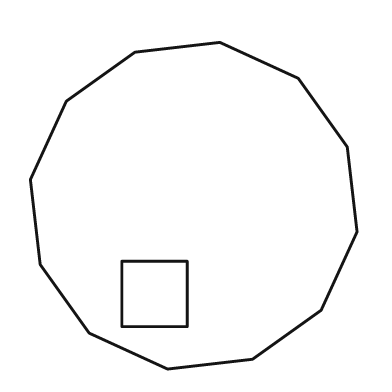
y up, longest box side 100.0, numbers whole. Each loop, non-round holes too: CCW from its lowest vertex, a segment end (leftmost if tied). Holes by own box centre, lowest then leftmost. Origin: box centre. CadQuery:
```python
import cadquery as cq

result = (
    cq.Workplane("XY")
    .moveTo(-8.0, -50.0)
    .lineTo(18.0, -47.0)
    .lineTo(39.0, -32.0)
    .lineTo(50.0, -8.0)
    .lineTo(47.0, 18.0)
    .lineTo(32.0, 39.0)
    .lineTo(8.0, 50.0)
    .lineTo(-18.0, 47.0)
    .lineTo(-39.0, 32.0)
    .lineTo(-50.0, 8.0)
    .lineTo(-47.0, -18.0)
    .lineTo(-32.0, -39.0)
    .close()
    .moveTo(-22.0, -37.0)
    .lineTo(-2.0, -37.0)
    .lineTo(-2.0, -17.0)
    .lineTo(-22.0, -17.0)
    .close()
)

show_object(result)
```